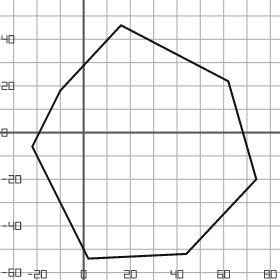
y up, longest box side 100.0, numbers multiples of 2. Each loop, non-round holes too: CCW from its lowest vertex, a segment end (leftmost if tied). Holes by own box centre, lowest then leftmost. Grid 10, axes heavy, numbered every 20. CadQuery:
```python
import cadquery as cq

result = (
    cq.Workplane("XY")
    .moveTo(2.0, -54.0)
    .lineTo(44.0, -52.0)
    .lineTo(74.0, -20.0)
    .lineTo(62.0, 22.0)
    .lineTo(16.0, 46.0)
    .lineTo(-10.0, 18.0)
    .lineTo(-22.0, -6.0)
    .close()
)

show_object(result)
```